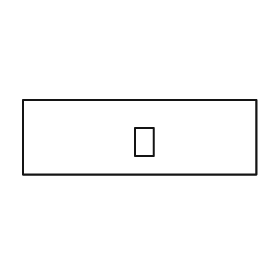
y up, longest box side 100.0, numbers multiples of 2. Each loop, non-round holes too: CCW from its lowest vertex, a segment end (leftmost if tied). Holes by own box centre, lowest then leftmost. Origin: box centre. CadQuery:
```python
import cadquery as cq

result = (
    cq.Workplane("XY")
    .moveTo(-50.0, -16.0)
    .lineTo(50.0, -16.0)
    .lineTo(50.0, 16.0)
    .lineTo(-50.0, 16.0)
    .close()
    .moveTo(-2.0, -8.0)
    .lineTo(6.0, -8.0)
    .lineTo(6.0, 4.0)
    .lineTo(-2.0, 4.0)
    .close()
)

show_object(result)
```